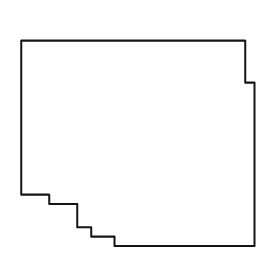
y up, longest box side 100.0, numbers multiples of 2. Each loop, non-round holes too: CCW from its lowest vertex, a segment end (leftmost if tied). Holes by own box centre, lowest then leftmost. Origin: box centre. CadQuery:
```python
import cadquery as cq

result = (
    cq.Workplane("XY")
    .moveTo(-10.0, -44.0)
    .lineTo(50.0, -44.0)
    .lineTo(50.0, 26.0)
    .lineTo(46.0, 26.0)
    .lineTo(46.0, 44.0)
    .lineTo(-50.0, 44.0)
    .lineTo(-50.0, -22.0)
    .lineTo(-38.0, -22.0)
    .lineTo(-38.0, -26.0)
    .lineTo(-26.0, -26.0)
    .lineTo(-26.0, -36.0)
    .lineTo(-20.0, -36.0)
    .lineTo(-20.0, -40.0)
    .lineTo(-10.0, -40.0)
    .close()
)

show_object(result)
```